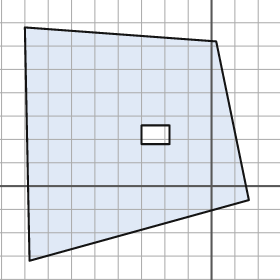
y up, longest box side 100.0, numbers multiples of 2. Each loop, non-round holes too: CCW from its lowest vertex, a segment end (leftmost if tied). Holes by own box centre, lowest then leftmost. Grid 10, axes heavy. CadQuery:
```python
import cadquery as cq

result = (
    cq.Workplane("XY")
    .moveTo(-78.0, -32.0)
    .lineTo(16.0, -6.0)
    .lineTo(2.0, 62.0)
    .lineTo(-80.0, 68.0)
    .close()
    .moveTo(-30.0, 18.0)
    .lineTo(-18.0, 18.0)
    .lineTo(-18.0, 26.0)
    .lineTo(-30.0, 26.0)
    .close()
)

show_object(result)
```